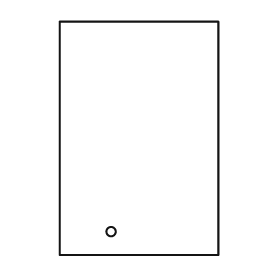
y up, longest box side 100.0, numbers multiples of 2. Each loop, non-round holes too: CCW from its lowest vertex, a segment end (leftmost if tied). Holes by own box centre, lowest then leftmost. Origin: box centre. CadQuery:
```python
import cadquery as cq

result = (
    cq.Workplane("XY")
    .moveTo(-34.0, -50.0)
    .lineTo(34.0, -50.0)
    .lineTo(34.0, 50.0)
    .lineTo(-34.0, 50.0)
    .close()
    .moveTo(-12.0, -40.0)
    .circle(2.0)
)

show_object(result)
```